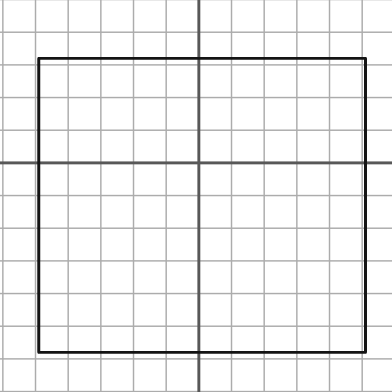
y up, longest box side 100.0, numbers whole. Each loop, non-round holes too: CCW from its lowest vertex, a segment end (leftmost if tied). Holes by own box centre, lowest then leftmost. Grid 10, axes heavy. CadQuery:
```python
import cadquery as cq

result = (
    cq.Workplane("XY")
    .moveTo(-49.0, -58.0)
    .lineTo(51.0, -58.0)
    .lineTo(51.0, 32.0)
    .lineTo(-49.0, 32.0)
    .close()
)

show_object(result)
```